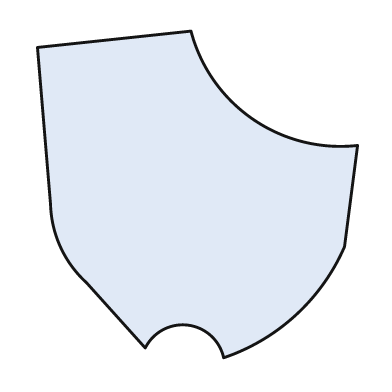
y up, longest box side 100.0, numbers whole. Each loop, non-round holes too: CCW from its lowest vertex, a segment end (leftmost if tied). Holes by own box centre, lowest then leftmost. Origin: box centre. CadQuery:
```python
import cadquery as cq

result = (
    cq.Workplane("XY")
    .moveTo(8.0, -50.0)
    .threePointArc((30.0, -37.0), (45.0, -16.0))
    .lineTo(49.0, 15.0)
    .threePointArc((17.0, 23.0), (-2.0, 50.0))
    .lineTo(-49.0, 45.0)
    .lineTo(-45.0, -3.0)
    .threePointArc((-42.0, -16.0), (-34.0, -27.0))
    .lineTo(-16.0, -47.0)
    .threePointArc((-3.0, -40.0), (8.0, -50.0))
    .close()
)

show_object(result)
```